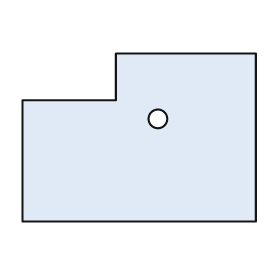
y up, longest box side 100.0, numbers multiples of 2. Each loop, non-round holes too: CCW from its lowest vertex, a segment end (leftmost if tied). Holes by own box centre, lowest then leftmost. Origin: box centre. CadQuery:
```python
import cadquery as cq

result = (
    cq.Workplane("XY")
    .moveTo(-50.0, -36.0)
    .lineTo(50.0, -36.0)
    .lineTo(50.0, 36.0)
    .lineTo(-10.0, 36.0)
    .lineTo(-10.0, 16.0)
    .lineTo(-50.0, 16.0)
    .close()
    .moveTo(8.0, 8.0)
    .circle(4.0)
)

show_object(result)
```